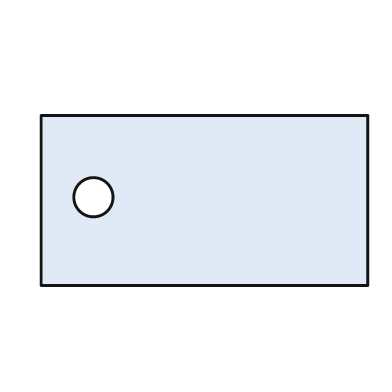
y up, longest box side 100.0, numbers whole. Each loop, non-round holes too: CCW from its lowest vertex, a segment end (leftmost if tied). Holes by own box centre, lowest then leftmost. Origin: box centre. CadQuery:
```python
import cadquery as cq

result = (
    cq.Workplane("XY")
    .moveTo(-50.0, -26.0)
    .lineTo(50.0, -26.0)
    .lineTo(50.0, 26.0)
    .lineTo(-50.0, 26.0)
    .close()
    .moveTo(-34.0, 1.0)
    .circle(6.0)
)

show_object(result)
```